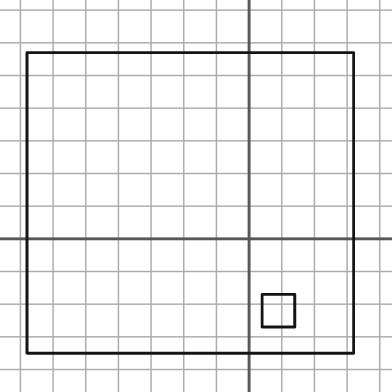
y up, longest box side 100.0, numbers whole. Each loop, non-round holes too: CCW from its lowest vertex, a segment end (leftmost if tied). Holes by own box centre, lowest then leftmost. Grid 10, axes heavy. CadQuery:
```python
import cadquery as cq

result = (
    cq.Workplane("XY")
    .moveTo(-68.0, -35.0)
    .lineTo(32.0, -35.0)
    .lineTo(32.0, 57.0)
    .lineTo(-68.0, 57.0)
    .close()
    .moveTo(4.0, -27.0)
    .lineTo(14.0, -27.0)
    .lineTo(14.0, -17.0)
    .lineTo(4.0, -17.0)
    .close()
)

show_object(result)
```